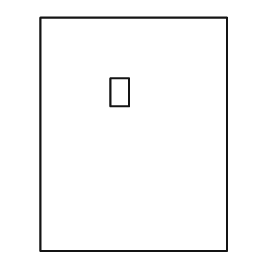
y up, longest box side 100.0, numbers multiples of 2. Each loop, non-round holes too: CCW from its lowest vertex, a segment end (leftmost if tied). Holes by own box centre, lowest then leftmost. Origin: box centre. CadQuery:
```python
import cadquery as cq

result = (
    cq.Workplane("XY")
    .moveTo(-40.0, -50.0)
    .lineTo(40.0, -50.0)
    .lineTo(40.0, 50.0)
    .lineTo(-40.0, 50.0)
    .close()
    .moveTo(-10.0, 12.0)
    .lineTo(-2.0, 12.0)
    .lineTo(-2.0, 24.0)
    .lineTo(-10.0, 24.0)
    .close()
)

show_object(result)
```